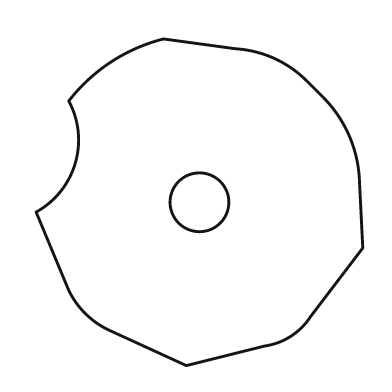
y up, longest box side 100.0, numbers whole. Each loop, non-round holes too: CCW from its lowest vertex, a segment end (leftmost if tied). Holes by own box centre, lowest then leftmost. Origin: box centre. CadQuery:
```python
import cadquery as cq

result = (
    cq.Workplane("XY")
    .moveTo(-4.0, -50.0)
    .lineTo(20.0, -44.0)
    .threePointArc((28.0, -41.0), (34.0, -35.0))
    .lineTo(50.0, -14.0)
    .lineTo(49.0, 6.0)
    .threePointArc((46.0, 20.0), (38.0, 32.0))
    .lineTo(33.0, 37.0)
    .threePointArc((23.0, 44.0), (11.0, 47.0))
    .lineTo(-11.0, 50.0)
    .threePointArc((-27.0, 43.0), (-40.0, 31.0))
    .threePointArc((-38.0, 12.0), (-50.0, -3.0))
    .lineTo(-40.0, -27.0)
    .threePointArc((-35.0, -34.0), (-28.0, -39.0))
    .close()
    .moveTo(0.0, 0.0)
    .circle(9.0)
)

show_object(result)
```